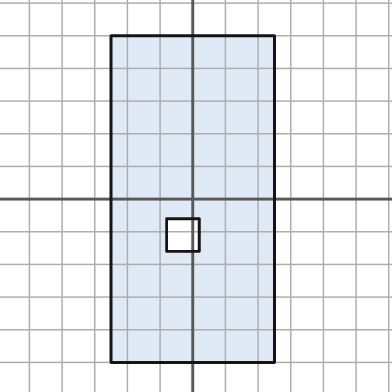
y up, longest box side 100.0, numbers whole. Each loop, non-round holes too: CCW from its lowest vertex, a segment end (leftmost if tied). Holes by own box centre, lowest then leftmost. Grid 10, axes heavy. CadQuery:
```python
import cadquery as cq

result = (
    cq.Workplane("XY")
    .moveTo(-25.0, -50.0)
    .lineTo(25.0, -50.0)
    .lineTo(25.0, 50.0)
    .lineTo(-25.0, 50.0)
    .close()
    .moveTo(-8.0, -16.0)
    .lineTo(2.0, -16.0)
    .lineTo(2.0, -6.0)
    .lineTo(-8.0, -6.0)
    .close()
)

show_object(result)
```